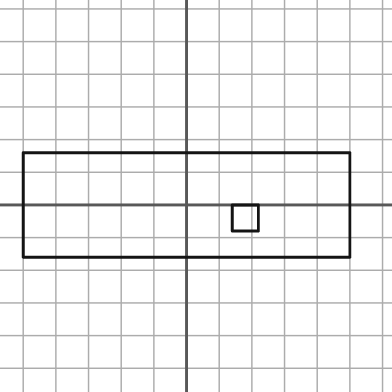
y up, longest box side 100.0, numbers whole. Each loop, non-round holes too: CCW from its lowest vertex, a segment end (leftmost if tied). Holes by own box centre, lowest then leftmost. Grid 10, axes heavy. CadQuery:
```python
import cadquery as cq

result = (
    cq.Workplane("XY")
    .moveTo(-50.0, -16.0)
    .lineTo(50.0, -16.0)
    .lineTo(50.0, 16.0)
    .lineTo(-50.0, 16.0)
    .close()
    .moveTo(14.0, -8.0)
    .lineTo(22.0, -8.0)
    .lineTo(22.0, 0.0)
    .lineTo(14.0, 0.0)
    .close()
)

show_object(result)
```